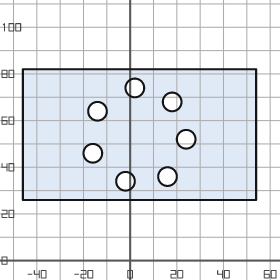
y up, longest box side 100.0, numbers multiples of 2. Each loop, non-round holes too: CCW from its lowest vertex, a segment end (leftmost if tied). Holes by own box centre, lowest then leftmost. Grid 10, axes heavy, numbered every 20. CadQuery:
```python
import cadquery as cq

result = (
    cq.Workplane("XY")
    .moveTo(-46.0, 26.0)
    .lineTo(54.0, 26.0)
    .lineTo(54.0, 82.0)
    .lineTo(-46.0, 82.0)
    .close()
    .moveTo(-2.0, 34.0)
    .circle(4.0)
    .moveTo(16.0, 36.0)
    .circle(4.0)
    .moveTo(-16.0, 46.0)
    .circle(4.0)
    .moveTo(24.0, 52.0)
    .circle(4.0)
    .moveTo(-14.0, 64.0)
    .circle(4.0)
    .moveTo(18.0, 68.0)
    .circle(4.0)
    .moveTo(2.0, 74.0)
    .circle(4.0)
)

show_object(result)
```